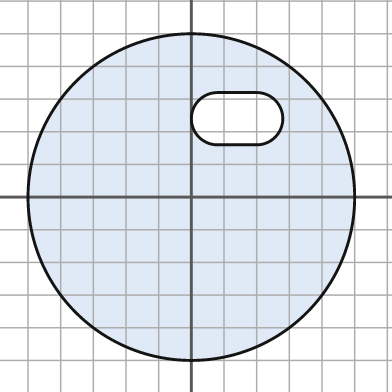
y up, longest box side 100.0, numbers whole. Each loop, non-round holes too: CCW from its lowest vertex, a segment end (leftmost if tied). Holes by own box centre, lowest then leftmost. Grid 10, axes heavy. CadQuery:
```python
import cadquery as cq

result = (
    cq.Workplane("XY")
    .moveTo(0.0, 0.0)
    .circle(50.0)
    .moveTo(8.0, 16.0)
    .lineTo(20.0, 16.0)
    .threePointArc((28.0, 24.0), (20.0, 32.0))
    .lineTo(8.0, 32.0)
    .threePointArc((0.0, 24.0), (8.0, 16.0))
    .close()
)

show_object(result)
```